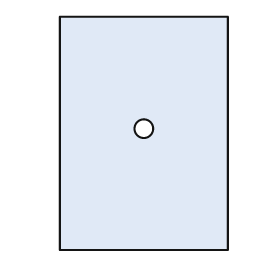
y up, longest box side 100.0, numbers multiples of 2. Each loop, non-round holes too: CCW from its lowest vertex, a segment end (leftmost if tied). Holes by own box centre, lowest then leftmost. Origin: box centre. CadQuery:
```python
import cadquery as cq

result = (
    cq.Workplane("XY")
    .moveTo(-36.0, -50.0)
    .lineTo(36.0, -50.0)
    .lineTo(36.0, 50.0)
    .lineTo(-36.0, 50.0)
    .close()
    .moveTo(0.0, 2.0)
    .circle(4.0)
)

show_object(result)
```